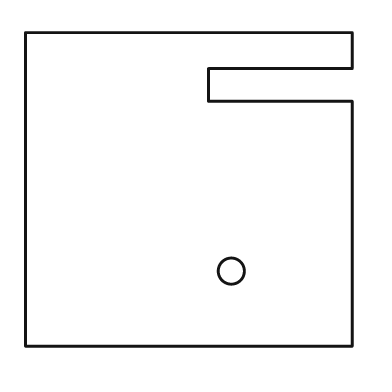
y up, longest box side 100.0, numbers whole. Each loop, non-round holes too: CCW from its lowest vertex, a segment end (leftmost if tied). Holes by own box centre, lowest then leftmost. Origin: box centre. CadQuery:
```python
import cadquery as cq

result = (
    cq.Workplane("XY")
    .moveTo(-50.0, -48.0)
    .lineTo(50.0, -48.0)
    .lineTo(50.0, 27.0)
    .lineTo(6.0, 27.0)
    .lineTo(6.0, 37.0)
    .lineTo(50.0, 37.0)
    .lineTo(50.0, 48.0)
    .lineTo(-50.0, 48.0)
    .close()
    .moveTo(13.0, -25.0)
    .circle(4.0)
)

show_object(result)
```